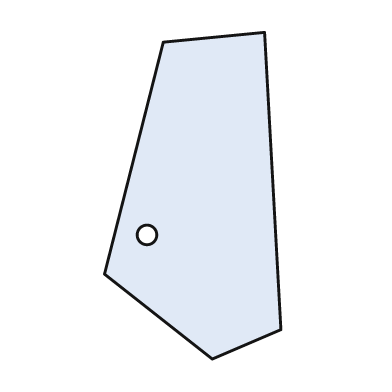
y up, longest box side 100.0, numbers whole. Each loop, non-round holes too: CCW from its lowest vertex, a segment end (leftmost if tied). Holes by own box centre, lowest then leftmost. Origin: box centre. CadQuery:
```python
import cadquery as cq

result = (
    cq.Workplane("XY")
    .moveTo(6.0, -50.0)
    .lineTo(27.0, -41.0)
    .lineTo(22.0, 50.0)
    .lineTo(-9.0, 47.0)
    .lineTo(-27.0, -24.0)
    .close()
    .moveTo(-14.0, -12.0)
    .circle(3.0)
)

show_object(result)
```